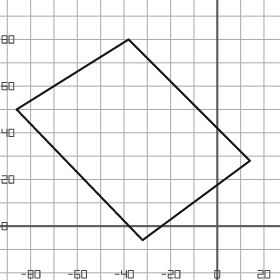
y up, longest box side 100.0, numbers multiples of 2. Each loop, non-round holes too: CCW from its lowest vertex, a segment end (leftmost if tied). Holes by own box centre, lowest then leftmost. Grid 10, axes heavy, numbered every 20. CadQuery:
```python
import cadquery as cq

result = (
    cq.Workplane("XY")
    .moveTo(-32.0, -6.0)
    .lineTo(14.0, 28.0)
    .lineTo(-38.0, 80.0)
    .lineTo(-86.0, 50.0)
    .close()
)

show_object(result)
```